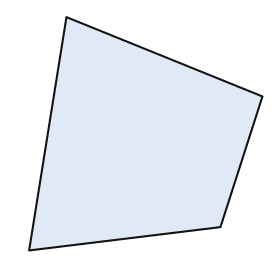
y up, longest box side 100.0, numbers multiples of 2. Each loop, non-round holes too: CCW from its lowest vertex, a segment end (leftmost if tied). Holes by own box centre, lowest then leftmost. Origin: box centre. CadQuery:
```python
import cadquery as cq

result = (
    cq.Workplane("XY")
    .moveTo(-50.0, -50.0)
    .lineTo(32.0, -40.0)
    .lineTo(50.0, 16.0)
    .lineTo(-34.0, 50.0)
    .close()
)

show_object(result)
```